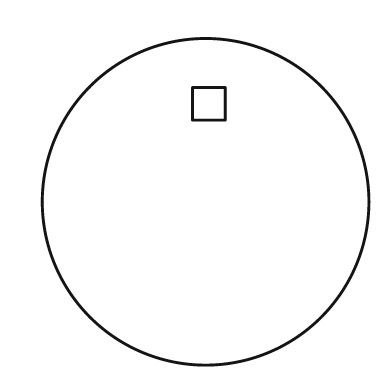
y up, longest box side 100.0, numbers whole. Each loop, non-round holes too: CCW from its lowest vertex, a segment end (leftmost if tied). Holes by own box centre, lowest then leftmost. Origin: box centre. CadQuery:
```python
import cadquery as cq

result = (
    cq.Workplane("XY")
    .moveTo(0.0, 0.0)
    .circle(50.0)
    .moveTo(-4.0, 25.0)
    .lineTo(6.0, 25.0)
    .lineTo(6.0, 35.0)
    .lineTo(-4.0, 35.0)
    .close()
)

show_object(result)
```